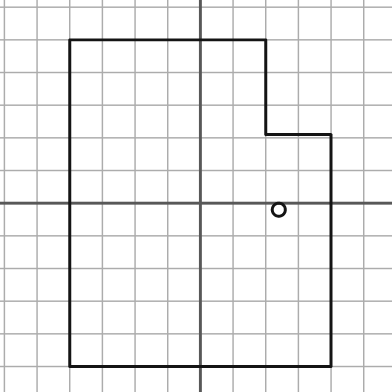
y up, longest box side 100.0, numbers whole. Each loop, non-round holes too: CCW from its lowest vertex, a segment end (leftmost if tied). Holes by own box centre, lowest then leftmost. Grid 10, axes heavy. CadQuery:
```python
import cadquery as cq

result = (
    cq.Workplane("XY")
    .moveTo(-40.0, -50.0)
    .lineTo(40.0, -50.0)
    .lineTo(40.0, 21.0)
    .lineTo(20.0, 21.0)
    .lineTo(20.0, 50.0)
    .lineTo(-40.0, 50.0)
    .close()
    .moveTo(24.0, -2.0)
    .circle(2.0)
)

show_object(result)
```